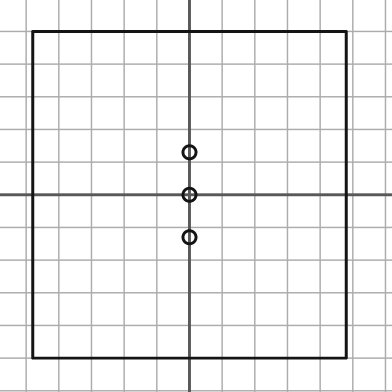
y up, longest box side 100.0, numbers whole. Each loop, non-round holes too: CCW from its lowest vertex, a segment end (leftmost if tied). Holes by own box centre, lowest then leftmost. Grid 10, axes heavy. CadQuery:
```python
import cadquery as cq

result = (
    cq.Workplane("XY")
    .moveTo(-48.0, -50.0)
    .lineTo(48.0, -50.0)
    .lineTo(48.0, 50.0)
    .lineTo(-48.0, 50.0)
    .close()
    .moveTo(0.0, -13.0)
    .circle(2.0)
    .moveTo(0.0, 0.0)
    .circle(2.0)
    .moveTo(0.0, 13.0)
    .circle(2.0)
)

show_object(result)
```